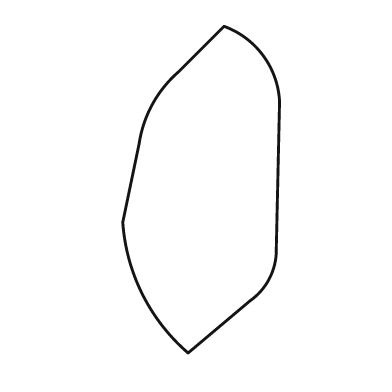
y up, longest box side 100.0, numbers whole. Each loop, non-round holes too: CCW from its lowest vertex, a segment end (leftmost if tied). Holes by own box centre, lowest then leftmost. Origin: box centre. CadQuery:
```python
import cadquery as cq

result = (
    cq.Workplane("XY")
    .moveTo(-4.0, -50.0)
    .lineTo(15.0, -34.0)
    .threePointArc((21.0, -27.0), (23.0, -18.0))
    .lineTo(24.0, 27.0)
    .threePointArc((19.0, 41.0), (7.0, 50.0))
    .lineTo(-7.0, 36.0)
    .threePointArc((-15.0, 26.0), (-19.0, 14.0))
    .lineTo(-24.0, -10.0)
    .threePointArc((-18.0, -32.0), (-4.0, -50.0))
    .close()
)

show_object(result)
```